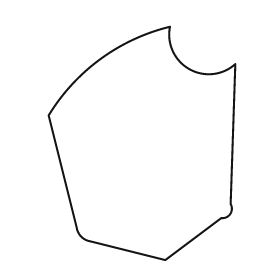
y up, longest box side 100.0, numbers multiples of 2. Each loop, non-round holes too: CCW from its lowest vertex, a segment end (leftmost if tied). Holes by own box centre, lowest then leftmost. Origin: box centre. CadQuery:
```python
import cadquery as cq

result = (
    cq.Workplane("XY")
    .moveTo(10.0, -50.0)
    .lineTo(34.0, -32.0)
    .threePointArc((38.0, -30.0), (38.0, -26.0))
    .lineTo(40.0, 34.0)
    .threePointArc((20.0, 32.0), (12.0, 50.0))
    .threePointArc((-18.0, 36.0), (-40.0, 12.0))
    .lineTo(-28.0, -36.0)
    .threePointArc((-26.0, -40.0), (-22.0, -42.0))
    .close()
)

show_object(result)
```